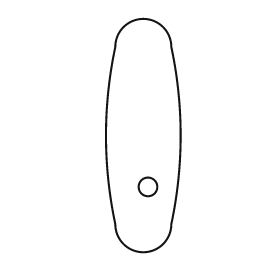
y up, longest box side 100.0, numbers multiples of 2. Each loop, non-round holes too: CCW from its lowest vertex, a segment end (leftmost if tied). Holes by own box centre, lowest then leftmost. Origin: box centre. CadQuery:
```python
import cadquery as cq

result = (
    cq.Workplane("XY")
    .moveTo(-12.0, -38.0)
    .threePointArc((0.0, -50.0), (12.0, -38.0))
    .threePointArc((16.0, 0.0), (12.0, 38.0))
    .threePointArc((0.0, 50.0), (-12.0, 38.0))
    .threePointArc((-16.0, 0.0), (-12.0, -38.0))
    .close()
    .moveTo(2.0, -22.0)
    .circle(4.0)
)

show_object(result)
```